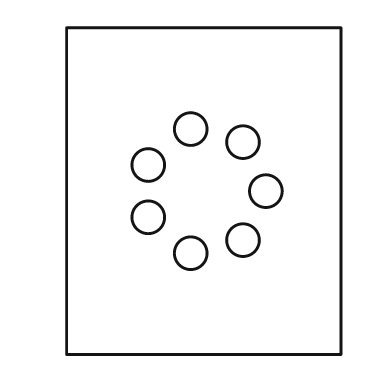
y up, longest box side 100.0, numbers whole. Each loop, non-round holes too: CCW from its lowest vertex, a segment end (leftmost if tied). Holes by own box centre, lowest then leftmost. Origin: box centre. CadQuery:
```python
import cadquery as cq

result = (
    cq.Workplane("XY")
    .moveTo(-42.0, -50.0)
    .lineTo(42.0, -50.0)
    .lineTo(42.0, 50.0)
    .lineTo(-42.0, 50.0)
    .close()
    .moveTo(-4.0, -19.0)
    .circle(5.0)
    .moveTo(12.0, -15.0)
    .circle(5.0)
    .moveTo(-17.0, -8.0)
    .circle(5.0)
    .moveTo(19.0, 0.0)
    .circle(5.0)
    .moveTo(-17.0, 8.0)
    .circle(5.0)
    .moveTo(12.0, 15.0)
    .circle(5.0)
    .moveTo(-4.0, 19.0)
    .circle(5.0)
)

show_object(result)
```